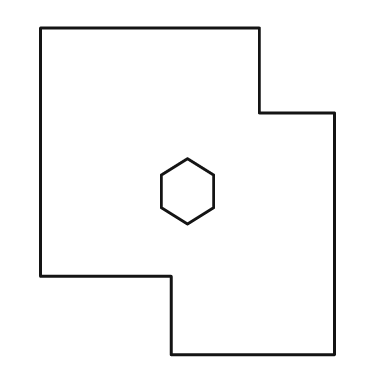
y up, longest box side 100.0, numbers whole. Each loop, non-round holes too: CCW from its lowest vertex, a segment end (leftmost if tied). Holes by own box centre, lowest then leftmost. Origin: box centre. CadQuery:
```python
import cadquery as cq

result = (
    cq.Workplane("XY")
    .moveTo(-5.0, -50.0)
    .lineTo(45.0, -50.0)
    .lineTo(45.0, 24.0)
    .lineTo(22.0, 24.0)
    .lineTo(22.0, 50.0)
    .lineTo(-45.0, 50.0)
    .lineTo(-45.0, -26.0)
    .lineTo(-5.0, -26.0)
    .close()
    .moveTo(0.0, -10.0)
    .lineTo(8.0, -5.0)
    .lineTo(8.0, 5.0)
    .lineTo(0.0, 10.0)
    .lineTo(-8.0, 5.0)
    .lineTo(-8.0, -5.0)
    .close()
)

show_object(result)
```